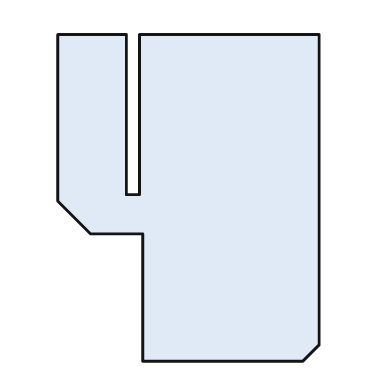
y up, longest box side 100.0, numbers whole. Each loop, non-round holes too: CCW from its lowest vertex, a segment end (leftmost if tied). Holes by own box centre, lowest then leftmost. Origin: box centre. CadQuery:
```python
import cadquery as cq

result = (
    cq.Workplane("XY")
    .moveTo(-14.0, -50.0)
    .lineTo(35.0, -50.0)
    .lineTo(40.0, -45.0)
    .lineTo(40.0, 50.0)
    .lineTo(-15.0, 50.0)
    .lineTo(-15.0, 1.0)
    .lineTo(-19.0, 1.0)
    .lineTo(-19.0, 50.0)
    .lineTo(-40.0, 50.0)
    .lineTo(-40.0, -1.0)
    .lineTo(-30.0, -11.0)
    .lineTo(-14.0, -11.0)
    .close()
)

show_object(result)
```